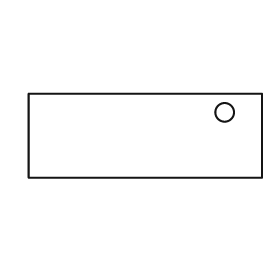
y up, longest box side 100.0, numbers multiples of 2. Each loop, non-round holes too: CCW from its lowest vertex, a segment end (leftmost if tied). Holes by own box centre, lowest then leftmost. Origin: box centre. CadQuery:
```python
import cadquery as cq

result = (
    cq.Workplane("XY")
    .moveTo(-50.0, -18.0)
    .lineTo(50.0, -18.0)
    .lineTo(50.0, 18.0)
    .lineTo(-50.0, 18.0)
    .close()
    .moveTo(34.0, 10.0)
    .circle(4.0)
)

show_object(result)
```